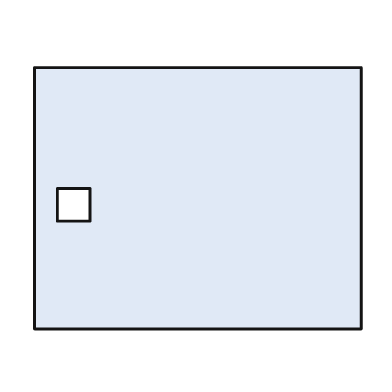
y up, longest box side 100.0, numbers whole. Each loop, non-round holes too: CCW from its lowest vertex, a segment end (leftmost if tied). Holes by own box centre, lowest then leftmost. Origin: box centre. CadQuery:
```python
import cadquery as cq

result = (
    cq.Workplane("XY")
    .moveTo(-50.0, -40.0)
    .lineTo(50.0, -40.0)
    .lineTo(50.0, 40.0)
    .lineTo(-50.0, 40.0)
    .close()
    .moveTo(-43.0, -7.0)
    .lineTo(-33.0, -7.0)
    .lineTo(-33.0, 3.0)
    .lineTo(-43.0, 3.0)
    .close()
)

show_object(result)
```